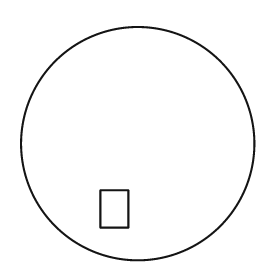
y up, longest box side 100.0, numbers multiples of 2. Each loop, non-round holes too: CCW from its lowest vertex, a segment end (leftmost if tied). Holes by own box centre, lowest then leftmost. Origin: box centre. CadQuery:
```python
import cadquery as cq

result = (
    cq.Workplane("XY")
    .moveTo(0.0, 0.0)
    .circle(50.0)
    .moveTo(-16.0, -36.0)
    .lineTo(-4.0, -36.0)
    .lineTo(-4.0, -20.0)
    .lineTo(-16.0, -20.0)
    .close()
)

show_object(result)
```